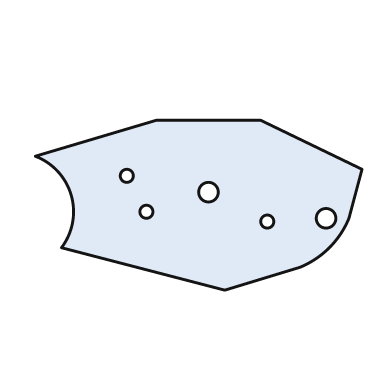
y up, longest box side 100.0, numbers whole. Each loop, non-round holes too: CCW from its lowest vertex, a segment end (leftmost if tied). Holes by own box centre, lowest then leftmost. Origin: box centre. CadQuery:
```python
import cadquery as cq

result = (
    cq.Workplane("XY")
    .moveTo(8.0, -26.0)
    .lineTo(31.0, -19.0)
    .threePointArc((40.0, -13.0), (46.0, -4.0))
    .lineTo(50.0, 11.0)
    .lineTo(19.0, 26.0)
    .lineTo(-13.0, 26.0)
    .lineTo(-50.0, 15.0)
    .threePointArc((-39.0, 3.0), (-42.0, -13.0))
    .close()
    .moveTo(21.0, -5.0)
    .circle(2.0)
    .moveTo(39.0, -4.0)
    .circle(3.0)
    .moveTo(-16.0, -2.0)
    .circle(2.0)
    .moveTo(3.0, 4.0)
    .circle(3.0)
    .moveTo(-22.0, 9.0)
    .circle(2.0)
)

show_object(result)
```